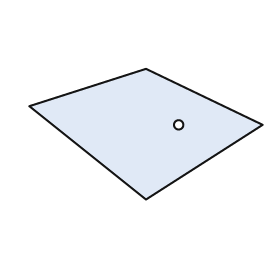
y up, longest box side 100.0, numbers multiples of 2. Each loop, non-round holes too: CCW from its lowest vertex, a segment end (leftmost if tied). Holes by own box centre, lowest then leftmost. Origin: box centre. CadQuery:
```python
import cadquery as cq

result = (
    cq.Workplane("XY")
    .moveTo(0.0, -28.0)
    .lineTo(50.0, 4.0)
    .lineTo(0.0, 28.0)
    .lineTo(-50.0, 12.0)
    .close()
    .moveTo(14.0, 4.0)
    .circle(2.0)
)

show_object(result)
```